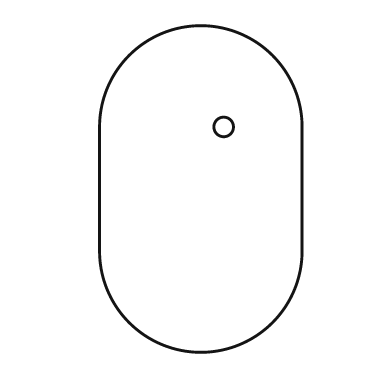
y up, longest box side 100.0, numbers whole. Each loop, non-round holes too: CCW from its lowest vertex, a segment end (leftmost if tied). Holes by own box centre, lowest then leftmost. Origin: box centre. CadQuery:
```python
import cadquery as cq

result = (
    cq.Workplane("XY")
    .moveTo(-31.0, -19.0)
    .threePointArc((0.0, -50.0), (31.0, -19.0))
    .lineTo(31.0, 19.0)
    .threePointArc((0.0, 50.0), (-31.0, 19.0))
    .close()
    .moveTo(7.0, 19.0)
    .circle(3.0)
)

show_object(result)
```